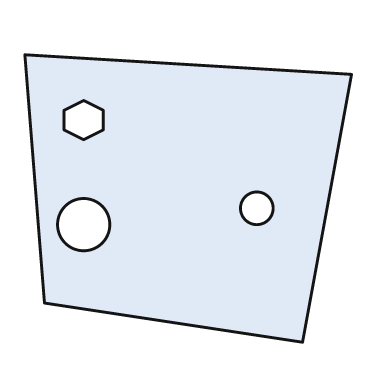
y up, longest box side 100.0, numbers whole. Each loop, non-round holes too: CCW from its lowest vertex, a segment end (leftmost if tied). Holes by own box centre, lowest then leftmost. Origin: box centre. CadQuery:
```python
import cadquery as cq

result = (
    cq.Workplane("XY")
    .moveTo(35.0, -44.0)
    .lineTo(50.0, 38.0)
    .lineTo(-50.0, 44.0)
    .lineTo(-44.0, -32.0)
    .close()
    .moveTo(-32.0, -8.0)
    .circle(8.0)
    .moveTo(21.0, -3.0)
    .circle(5.0)
    .moveTo(-32.0, 18.0)
    .lineTo(-26.0, 21.0)
    .lineTo(-26.0, 27.0)
    .lineTo(-32.0, 30.0)
    .lineTo(-38.0, 27.0)
    .lineTo(-38.0, 21.0)
    .close()
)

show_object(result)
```